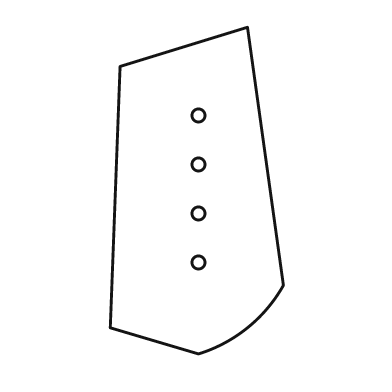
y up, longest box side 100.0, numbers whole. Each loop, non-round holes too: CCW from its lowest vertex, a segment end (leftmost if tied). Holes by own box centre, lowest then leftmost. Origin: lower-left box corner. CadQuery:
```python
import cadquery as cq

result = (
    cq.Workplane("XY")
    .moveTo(27.0, 0.0)
    .threePointArc((42.0, 8.0), (53.0, 21.0))
    .lineTo(42.0, 100.0)
    .lineTo(3.0, 88.0)
    .lineTo(0.0, 8.0)
    .close()
    .moveTo(27.0, 28.0)
    .circle(2.0)
    .moveTo(27.0, 43.0)
    .circle(2.0)
    .moveTo(27.0, 58.0)
    .circle(2.0)
    .moveTo(27.0, 73.0)
    .circle(2.0)
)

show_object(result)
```